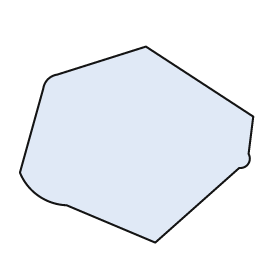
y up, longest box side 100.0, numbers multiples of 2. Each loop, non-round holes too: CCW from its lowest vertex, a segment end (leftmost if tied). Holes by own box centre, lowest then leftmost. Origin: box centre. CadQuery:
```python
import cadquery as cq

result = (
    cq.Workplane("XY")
    .moveTo(8.0, -42.0)
    .lineTo(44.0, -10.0)
    .threePointArc((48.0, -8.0), (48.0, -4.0))
    .lineTo(50.0, 12.0)
    .lineTo(4.0, 42.0)
    .lineTo(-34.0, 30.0)
    .threePointArc((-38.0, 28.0), (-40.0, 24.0))
    .lineTo(-50.0, -12.0)
    .threePointArc((-42.0, -22.0), (-30.0, -26.0))
    .close()
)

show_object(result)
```